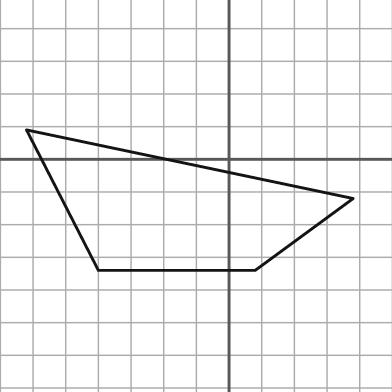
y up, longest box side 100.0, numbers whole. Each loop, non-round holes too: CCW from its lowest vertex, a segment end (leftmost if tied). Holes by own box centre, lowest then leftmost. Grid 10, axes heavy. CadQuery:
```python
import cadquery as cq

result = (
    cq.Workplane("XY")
    .moveTo(-40.0, -34.0)
    .lineTo(8.0, -34.0)
    .lineTo(38.0, -12.0)
    .lineTo(-62.0, 9.0)
    .close()
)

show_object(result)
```